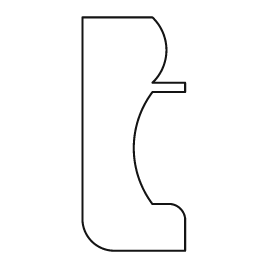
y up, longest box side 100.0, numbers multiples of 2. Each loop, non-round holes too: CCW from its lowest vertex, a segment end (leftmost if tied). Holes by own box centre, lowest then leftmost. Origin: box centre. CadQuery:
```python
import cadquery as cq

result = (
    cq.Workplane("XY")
    .moveTo(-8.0, -50.0)
    .lineTo(22.0, -50.0)
    .lineTo(22.0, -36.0)
    .threePointArc((20.0, -32.0), (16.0, -30.0))
    .lineTo(8.0, -30.0)
    .threePointArc((0.0, -6.0), (8.0, 18.0))
    .lineTo(22.0, 18.0)
    .lineTo(22.0, 22.0)
    .lineTo(8.0, 22.0)
    .threePointArc((14.0, 36.0), (8.0, 50.0))
    .lineTo(-22.0, 50.0)
    .lineTo(-22.0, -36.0)
    .threePointArc((-18.0, -46.0), (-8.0, -50.0))
    .close()
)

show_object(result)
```